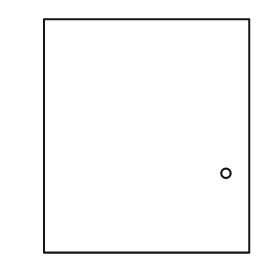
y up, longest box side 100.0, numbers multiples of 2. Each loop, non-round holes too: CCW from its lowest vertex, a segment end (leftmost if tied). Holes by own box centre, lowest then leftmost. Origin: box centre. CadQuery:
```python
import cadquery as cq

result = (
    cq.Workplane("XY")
    .moveTo(-44.0, -50.0)
    .lineTo(44.0, -50.0)
    .lineTo(44.0, 50.0)
    .lineTo(-44.0, 50.0)
    .close()
    .moveTo(34.0, -16.0)
    .circle(2.0)
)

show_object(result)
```